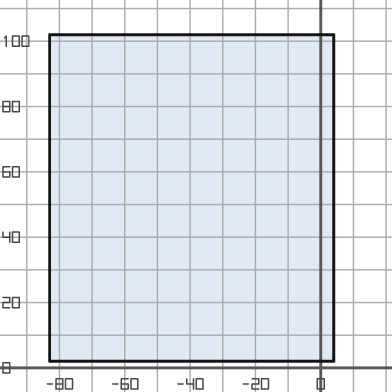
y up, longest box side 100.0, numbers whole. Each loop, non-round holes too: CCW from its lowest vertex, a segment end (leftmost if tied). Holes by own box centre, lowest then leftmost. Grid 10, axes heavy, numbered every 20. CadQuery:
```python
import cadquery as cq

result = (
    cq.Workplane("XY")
    .moveTo(-83.0, 2.0)
    .lineTo(4.0, 2.0)
    .lineTo(4.0, 102.0)
    .lineTo(-83.0, 102.0)
    .close()
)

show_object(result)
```